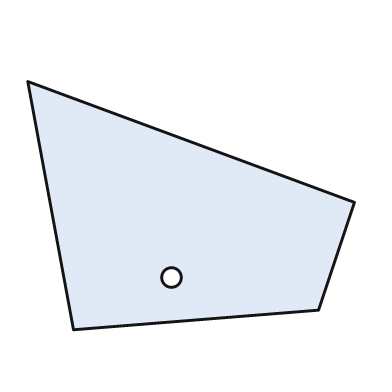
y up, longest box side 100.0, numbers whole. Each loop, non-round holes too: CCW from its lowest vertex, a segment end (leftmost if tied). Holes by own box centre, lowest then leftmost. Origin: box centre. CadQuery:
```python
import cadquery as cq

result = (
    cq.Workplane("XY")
    .moveTo(-36.0, -38.0)
    .lineTo(39.0, -32.0)
    .lineTo(50.0, 1.0)
    .lineTo(-50.0, 38.0)
    .close()
    .moveTo(-6.0, -22.0)
    .circle(3.0)
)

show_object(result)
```